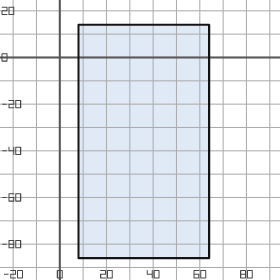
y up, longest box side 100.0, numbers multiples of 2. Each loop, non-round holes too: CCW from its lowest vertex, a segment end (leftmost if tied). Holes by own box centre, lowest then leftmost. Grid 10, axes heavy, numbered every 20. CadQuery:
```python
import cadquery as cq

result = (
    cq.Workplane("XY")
    .moveTo(8.0, -86.0)
    .lineTo(64.0, -86.0)
    .lineTo(64.0, 14.0)
    .lineTo(8.0, 14.0)
    .close()
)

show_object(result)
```